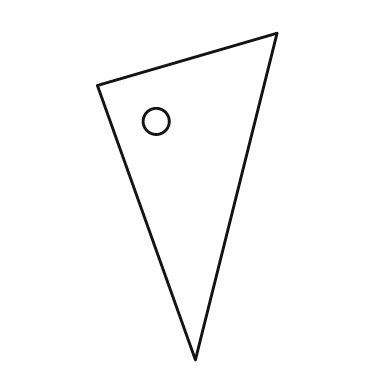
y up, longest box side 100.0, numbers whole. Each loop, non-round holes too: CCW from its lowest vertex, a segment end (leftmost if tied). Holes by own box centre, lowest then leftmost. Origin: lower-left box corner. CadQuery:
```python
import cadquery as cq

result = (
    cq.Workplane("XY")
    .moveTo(30.0, 0.0)
    .lineTo(55.0, 100.0)
    .lineTo(0.0, 84.0)
    .close()
    .moveTo(18.0, 73.0)
    .circle(4.0)
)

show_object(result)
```